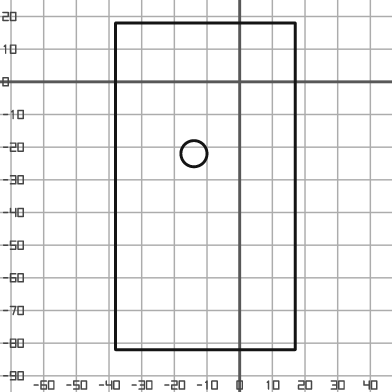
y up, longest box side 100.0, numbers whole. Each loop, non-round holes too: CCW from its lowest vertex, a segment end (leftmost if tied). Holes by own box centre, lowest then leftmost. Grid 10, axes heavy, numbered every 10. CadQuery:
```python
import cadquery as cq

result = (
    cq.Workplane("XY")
    .moveTo(-38.0, -82.0)
    .lineTo(17.0, -82.0)
    .lineTo(17.0, 18.0)
    .lineTo(-38.0, 18.0)
    .close()
    .moveTo(-14.0, -22.0)
    .circle(4.0)
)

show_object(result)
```